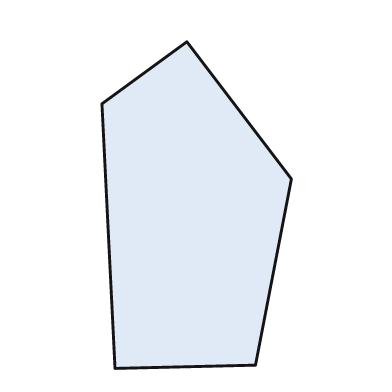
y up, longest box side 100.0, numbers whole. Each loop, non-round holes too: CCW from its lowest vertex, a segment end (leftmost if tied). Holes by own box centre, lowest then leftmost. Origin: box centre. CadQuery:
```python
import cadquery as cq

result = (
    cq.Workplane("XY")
    .moveTo(-25.0, -50.0)
    .lineTo(18.0, -49.0)
    .lineTo(29.0, 8.0)
    .lineTo(-3.0, 50.0)
    .lineTo(-29.0, 31.0)
    .close()
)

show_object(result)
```